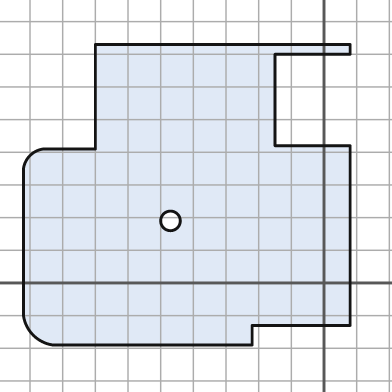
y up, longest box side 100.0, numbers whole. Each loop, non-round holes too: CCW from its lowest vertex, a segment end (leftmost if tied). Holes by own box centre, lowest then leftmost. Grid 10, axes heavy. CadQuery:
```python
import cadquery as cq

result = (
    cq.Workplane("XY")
    .moveTo(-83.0, -19.0)
    .lineTo(-22.0, -19.0)
    .lineTo(-22.0, -13.0)
    .lineTo(8.0, -13.0)
    .lineTo(8.0, 42.0)
    .lineTo(-15.0, 42.0)
    .lineTo(-15.0, 70.0)
    .lineTo(8.0, 70.0)
    .lineTo(8.0, 73.0)
    .lineTo(-70.0, 73.0)
    .lineTo(-70.0, 41.0)
    .lineTo(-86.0, 41.0)
    .threePointArc((-90.0, 39.0), (-92.0, 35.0))
    .lineTo(-92.0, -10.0)
    .threePointArc((-89.0, -16.0), (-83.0, -19.0))
    .close()
    .moveTo(-47.0, 19.0)
    .circle(3.0)
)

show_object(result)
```